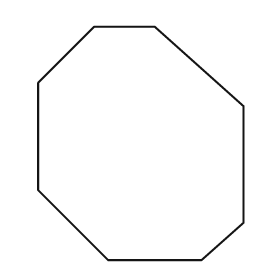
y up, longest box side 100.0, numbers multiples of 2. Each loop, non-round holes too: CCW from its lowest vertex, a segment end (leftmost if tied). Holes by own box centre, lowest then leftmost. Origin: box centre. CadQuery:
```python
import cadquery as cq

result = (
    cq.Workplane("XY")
    .moveTo(-14.0, -50.0)
    .lineTo(26.0, -50.0)
    .lineTo(44.0, -34.0)
    .lineTo(44.0, 16.0)
    .lineTo(6.0, 50.0)
    .lineTo(-20.0, 50.0)
    .lineTo(-44.0, 26.0)
    .lineTo(-44.0, -20.0)
    .close()
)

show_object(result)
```